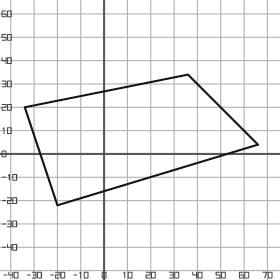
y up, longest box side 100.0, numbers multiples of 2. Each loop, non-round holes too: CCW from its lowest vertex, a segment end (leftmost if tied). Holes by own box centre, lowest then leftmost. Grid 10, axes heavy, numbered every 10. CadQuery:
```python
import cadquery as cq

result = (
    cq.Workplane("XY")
    .moveTo(-20.0, -22.0)
    .lineTo(66.0, 4.0)
    .lineTo(36.0, 34.0)
    .lineTo(-34.0, 20.0)
    .close()
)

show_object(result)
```